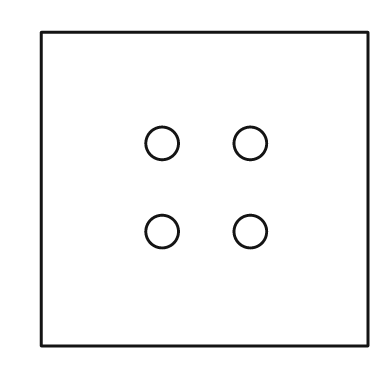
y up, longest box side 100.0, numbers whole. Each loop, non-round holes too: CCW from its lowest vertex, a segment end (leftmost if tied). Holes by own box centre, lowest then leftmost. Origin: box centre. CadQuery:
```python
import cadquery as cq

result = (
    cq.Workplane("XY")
    .moveTo(-50.0, -48.0)
    .lineTo(50.0, -48.0)
    .lineTo(50.0, 48.0)
    .lineTo(-50.0, 48.0)
    .close()
    .moveTo(-13.0, -13.0)
    .circle(5.0)
    .moveTo(14.0, -13.0)
    .circle(5.0)
    .moveTo(-13.0, 14.0)
    .circle(5.0)
    .moveTo(14.0, 14.0)
    .circle(5.0)
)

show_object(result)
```